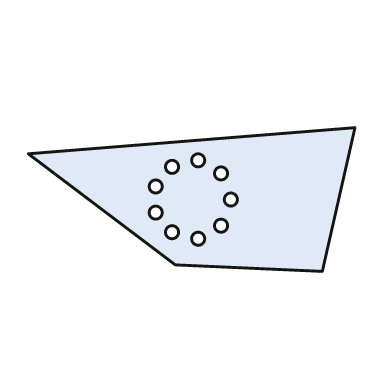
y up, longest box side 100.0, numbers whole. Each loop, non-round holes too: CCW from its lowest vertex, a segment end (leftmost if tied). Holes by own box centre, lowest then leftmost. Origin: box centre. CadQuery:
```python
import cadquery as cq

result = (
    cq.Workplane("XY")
    .moveTo(40.0, -22.0)
    .lineTo(50.0, 22.0)
    .lineTo(-50.0, 14.0)
    .lineTo(-5.0, -20.0)
    .close()
    .moveTo(2.0, -12.0)
    .circle(2.0)
    .moveTo(-6.0, -10.0)
    .circle(2.0)
    .moveTo(9.0, -8.0)
    .circle(2.0)
    .moveTo(-11.0, -4.0)
    .circle(2.0)
    .moveTo(12.0, 0.0)
    .circle(2.0)
    .moveTo(-11.0, 4.0)
    .circle(2.0)
    .moveTo(9.0, 8.0)
    .circle(2.0)
    .moveTo(-6.0, 10.0)
    .circle(2.0)
    .moveTo(2.0, 12.0)
    .circle(2.0)
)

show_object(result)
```